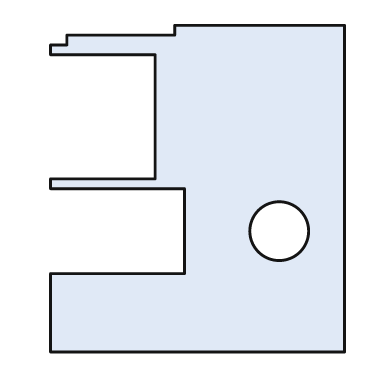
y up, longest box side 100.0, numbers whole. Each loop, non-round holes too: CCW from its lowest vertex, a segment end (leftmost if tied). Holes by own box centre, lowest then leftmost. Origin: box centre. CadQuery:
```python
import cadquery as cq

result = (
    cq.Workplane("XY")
    .moveTo(-45.0, -50.0)
    .lineTo(45.0, -50.0)
    .lineTo(45.0, 50.0)
    .lineTo(-7.0, 50.0)
    .lineTo(-7.0, 47.0)
    .lineTo(-40.0, 47.0)
    .lineTo(-40.0, 44.0)
    .lineTo(-45.0, 44.0)
    .lineTo(-45.0, 41.0)
    .lineTo(-13.0, 41.0)
    .lineTo(-13.0, 3.0)
    .lineTo(-45.0, 3.0)
    .lineTo(-45.0, 0.0)
    .lineTo(-4.0, 0.0)
    .lineTo(-4.0, -26.0)
    .lineTo(-45.0, -26.0)
    .close()
    .moveTo(25.0, -13.0)
    .circle(9.0)
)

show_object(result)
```